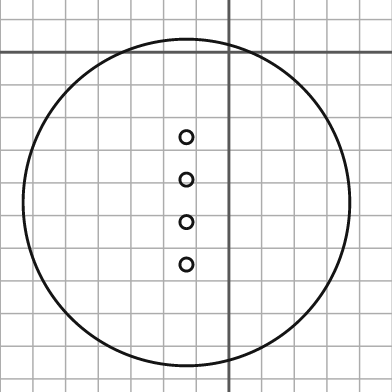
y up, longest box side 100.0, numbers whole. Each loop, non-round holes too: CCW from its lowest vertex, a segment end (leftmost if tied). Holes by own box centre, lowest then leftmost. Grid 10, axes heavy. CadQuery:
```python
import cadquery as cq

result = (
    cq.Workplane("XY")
    .moveTo(-13.0, -46.0)
    .circle(50.0)
    .moveTo(-13.0, -65.0)
    .circle(2.0)
    .moveTo(-13.0, -52.0)
    .circle(2.0)
    .moveTo(-13.0, -39.0)
    .circle(2.0)
    .moveTo(-13.0, -26.0)
    .circle(2.0)
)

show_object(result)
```